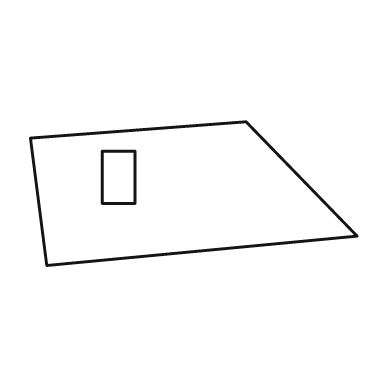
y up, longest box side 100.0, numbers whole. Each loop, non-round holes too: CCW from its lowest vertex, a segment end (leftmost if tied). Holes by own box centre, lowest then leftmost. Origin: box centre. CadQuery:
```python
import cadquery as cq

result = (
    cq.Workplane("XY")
    .moveTo(-45.0, -22.0)
    .lineTo(50.0, -13.0)
    .lineTo(16.0, 22.0)
    .lineTo(-50.0, 17.0)
    .close()
    .moveTo(-28.0, -3.0)
    .lineTo(-18.0, -3.0)
    .lineTo(-18.0, 13.0)
    .lineTo(-28.0, 13.0)
    .close()
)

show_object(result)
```